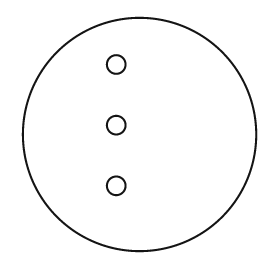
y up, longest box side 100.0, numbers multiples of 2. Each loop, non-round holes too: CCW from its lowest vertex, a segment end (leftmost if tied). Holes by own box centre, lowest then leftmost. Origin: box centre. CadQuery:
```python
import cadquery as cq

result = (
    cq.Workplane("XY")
    .moveTo(0.0, 0.0)
    .circle(50.0)
    .moveTo(-10.0, -22.0)
    .circle(4.0)
    .moveTo(-10.0, 4.0)
    .circle(4.0)
    .moveTo(-10.0, 30.0)
    .circle(4.0)
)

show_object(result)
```